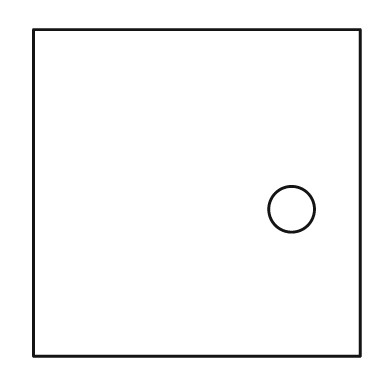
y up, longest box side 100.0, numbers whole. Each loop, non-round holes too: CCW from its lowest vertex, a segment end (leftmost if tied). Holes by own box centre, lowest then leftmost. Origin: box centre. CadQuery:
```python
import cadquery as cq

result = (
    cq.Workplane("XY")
    .moveTo(-50.0, -50.0)
    .lineTo(50.0, -50.0)
    .lineTo(50.0, 50.0)
    .lineTo(-50.0, 50.0)
    .close()
    .moveTo(29.0, -5.0)
    .circle(7.0)
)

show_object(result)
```